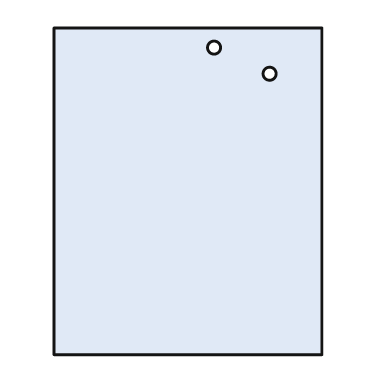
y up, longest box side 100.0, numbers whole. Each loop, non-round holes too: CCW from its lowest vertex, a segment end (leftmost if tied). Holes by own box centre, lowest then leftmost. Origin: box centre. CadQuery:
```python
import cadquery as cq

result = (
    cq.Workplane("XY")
    .moveTo(-41.0, -50.0)
    .lineTo(41.0, -50.0)
    .lineTo(41.0, 50.0)
    .lineTo(-41.0, 50.0)
    .close()
    .moveTo(25.0, 36.0)
    .circle(2.0)
    .moveTo(8.0, 44.0)
    .circle(2.0)
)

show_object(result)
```